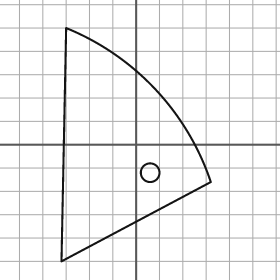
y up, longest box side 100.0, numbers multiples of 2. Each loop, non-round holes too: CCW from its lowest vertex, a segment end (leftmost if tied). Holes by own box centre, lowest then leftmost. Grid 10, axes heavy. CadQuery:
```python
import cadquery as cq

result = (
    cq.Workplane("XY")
    .moveTo(-32.0, -50.0)
    .lineTo(32.0, -16.0)
    .threePointArc((8.0, 24.0), (-30.0, 50.0))
    .close()
    .moveTo(6.0, -12.0)
    .circle(4.0)
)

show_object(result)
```